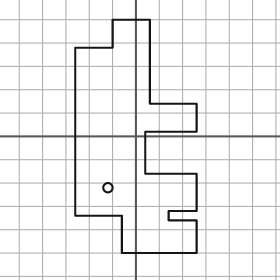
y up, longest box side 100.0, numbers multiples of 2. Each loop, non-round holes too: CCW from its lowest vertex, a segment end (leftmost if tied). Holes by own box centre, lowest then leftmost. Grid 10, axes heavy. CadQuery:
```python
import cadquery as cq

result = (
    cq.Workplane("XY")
    .moveTo(-6.0, -50.0)
    .lineTo(26.0, -50.0)
    .lineTo(26.0, -36.0)
    .lineTo(14.0, -36.0)
    .lineTo(14.0, -32.0)
    .lineTo(26.0, -32.0)
    .lineTo(26.0, -16.0)
    .lineTo(4.0, -16.0)
    .lineTo(4.0, 2.0)
    .lineTo(26.0, 2.0)
    .lineTo(26.0, 14.0)
    .lineTo(6.0, 14.0)
    .lineTo(6.0, 50.0)
    .lineTo(-10.0, 50.0)
    .lineTo(-10.0, 38.0)
    .lineTo(-26.0, 38.0)
    .lineTo(-26.0, -34.0)
    .lineTo(-6.0, -34.0)
    .close()
    .moveTo(-12.0, -22.0)
    .circle(2.0)
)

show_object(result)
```